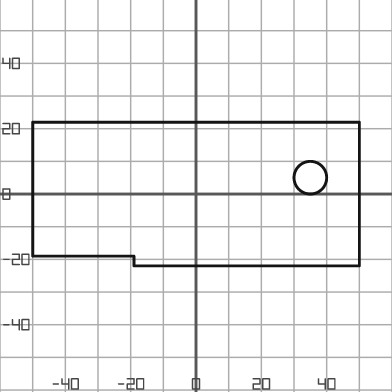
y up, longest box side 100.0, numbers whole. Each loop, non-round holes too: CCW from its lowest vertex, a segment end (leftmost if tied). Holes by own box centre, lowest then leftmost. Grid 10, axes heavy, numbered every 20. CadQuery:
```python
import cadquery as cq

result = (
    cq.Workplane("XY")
    .moveTo(-19.0, -22.0)
    .lineTo(50.0, -22.0)
    .lineTo(50.0, 22.0)
    .lineTo(-50.0, 22.0)
    .lineTo(-50.0, -19.0)
    .lineTo(-19.0, -19.0)
    .close()
    .moveTo(35.0, 5.0)
    .circle(5.0)
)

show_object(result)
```